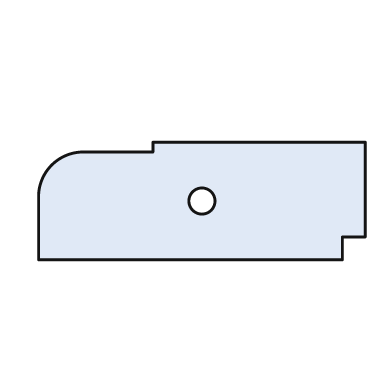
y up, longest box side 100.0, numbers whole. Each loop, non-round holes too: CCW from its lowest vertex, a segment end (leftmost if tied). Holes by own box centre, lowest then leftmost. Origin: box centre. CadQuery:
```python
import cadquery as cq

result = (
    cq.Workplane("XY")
    .moveTo(-50.0, -18.0)
    .lineTo(43.0, -18.0)
    .lineTo(43.0, -11.0)
    .lineTo(50.0, -11.0)
    .lineTo(50.0, 18.0)
    .lineTo(-15.0, 18.0)
    .lineTo(-15.0, 15.0)
    .lineTo(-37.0, 15.0)
    .threePointArc((-46.0, 11.0), (-50.0, 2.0))
    .close()
    .moveTo(0.0, 0.0)
    .circle(4.0)
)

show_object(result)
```